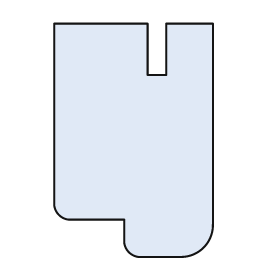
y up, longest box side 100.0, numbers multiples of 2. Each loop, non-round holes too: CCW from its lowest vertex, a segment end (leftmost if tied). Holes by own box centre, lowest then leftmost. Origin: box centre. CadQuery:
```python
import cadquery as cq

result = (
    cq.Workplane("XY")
    .moveTo(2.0, -50.0)
    .lineTo(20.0, -50.0)
    .threePointArc((30.0, -46.0), (34.0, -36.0))
    .lineTo(34.0, 50.0)
    .lineTo(14.0, 50.0)
    .lineTo(14.0, 28.0)
    .lineTo(6.0, 28.0)
    .lineTo(6.0, 50.0)
    .lineTo(-34.0, 50.0)
    .lineTo(-34.0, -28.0)
    .threePointArc((-32.0, -32.0), (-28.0, -34.0))
    .lineTo(-4.0, -34.0)
    .lineTo(-4.0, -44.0)
    .threePointArc((-2.0, -48.0), (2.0, -50.0))
    .close()
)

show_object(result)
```